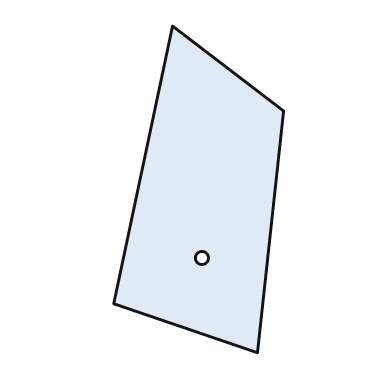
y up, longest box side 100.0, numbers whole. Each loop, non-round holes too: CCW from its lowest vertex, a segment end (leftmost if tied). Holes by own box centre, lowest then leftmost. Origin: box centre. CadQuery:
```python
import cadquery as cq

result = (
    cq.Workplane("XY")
    .moveTo(18.0, -50.0)
    .lineTo(26.0, 24.0)
    .lineTo(-8.0, 50.0)
    .lineTo(-26.0, -35.0)
    .close()
    .moveTo(1.0, -21.0)
    .circle(2.0)
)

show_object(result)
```